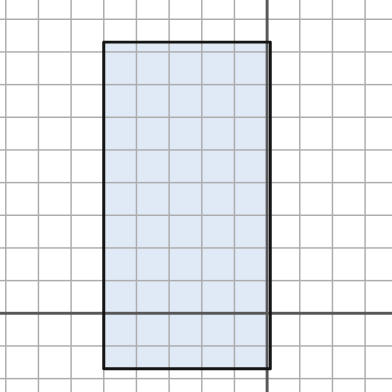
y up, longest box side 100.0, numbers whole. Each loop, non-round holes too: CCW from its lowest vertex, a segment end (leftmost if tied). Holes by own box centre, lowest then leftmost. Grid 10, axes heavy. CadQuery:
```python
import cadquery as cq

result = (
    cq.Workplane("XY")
    .moveTo(-50.0, -17.0)
    .lineTo(1.0, -17.0)
    .lineTo(1.0, 83.0)
    .lineTo(-50.0, 83.0)
    .close()
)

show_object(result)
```